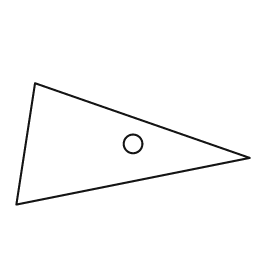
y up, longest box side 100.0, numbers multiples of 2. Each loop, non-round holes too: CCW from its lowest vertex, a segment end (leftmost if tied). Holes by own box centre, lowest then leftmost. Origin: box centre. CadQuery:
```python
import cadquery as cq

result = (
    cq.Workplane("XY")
    .moveTo(-50.0, -26.0)
    .lineTo(50.0, -6.0)
    .lineTo(-42.0, 26.0)
    .close()
    .moveTo(0.0, 0.0)
    .circle(4.0)
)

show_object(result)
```